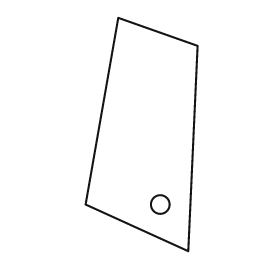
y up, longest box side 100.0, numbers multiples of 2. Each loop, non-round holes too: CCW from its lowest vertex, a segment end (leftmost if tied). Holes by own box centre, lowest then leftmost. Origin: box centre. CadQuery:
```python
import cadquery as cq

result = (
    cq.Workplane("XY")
    .moveTo(20.0, -50.0)
    .lineTo(24.0, 38.0)
    .lineTo(-10.0, 50.0)
    .lineTo(-24.0, -30.0)
    .close()
    .moveTo(8.0, -30.0)
    .circle(4.0)
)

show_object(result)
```